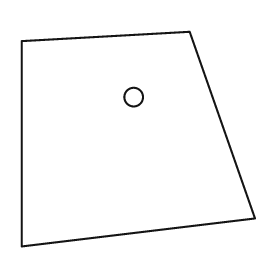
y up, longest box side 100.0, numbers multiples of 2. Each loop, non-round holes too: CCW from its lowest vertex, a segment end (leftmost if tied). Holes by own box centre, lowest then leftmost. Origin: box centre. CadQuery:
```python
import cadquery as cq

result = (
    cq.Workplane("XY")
    .moveTo(-50.0, -46.0)
    .lineTo(50.0, -34.0)
    .lineTo(22.0, 46.0)
    .lineTo(-50.0, 42.0)
    .close()
    .moveTo(-2.0, 18.0)
    .circle(4.0)
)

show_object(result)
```